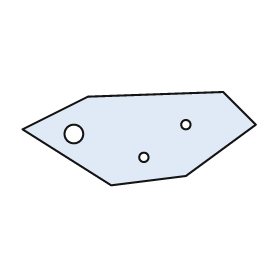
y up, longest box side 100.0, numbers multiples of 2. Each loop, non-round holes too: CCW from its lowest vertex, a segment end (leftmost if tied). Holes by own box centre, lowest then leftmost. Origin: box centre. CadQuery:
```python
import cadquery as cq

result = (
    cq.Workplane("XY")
    .moveTo(-12.0, -20.0)
    .lineTo(20.0, -16.0)
    .lineTo(50.0, 6.0)
    .lineTo(36.0, 20.0)
    .lineTo(-22.0, 18.0)
    .lineTo(-50.0, 4.0)
    .close()
    .moveTo(2.0, -8.0)
    .circle(2.0)
    .moveTo(-28.0, 2.0)
    .circle(4.0)
    .moveTo(20.0, 6.0)
    .circle(2.0)
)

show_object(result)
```